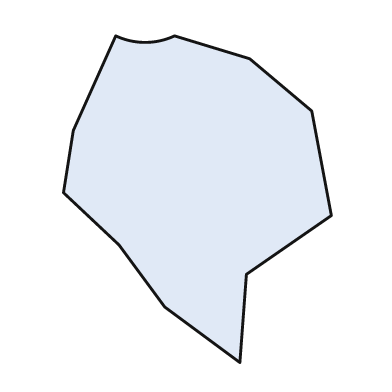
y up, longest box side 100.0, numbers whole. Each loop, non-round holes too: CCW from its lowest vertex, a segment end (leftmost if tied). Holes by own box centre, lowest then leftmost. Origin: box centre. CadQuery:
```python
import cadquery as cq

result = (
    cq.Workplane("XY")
    .moveTo(13.0, -50.0)
    .lineTo(15.0, -23.0)
    .lineTo(41.0, -5.0)
    .lineTo(35.0, 27.0)
    .lineTo(16.0, 43.0)
    .lineTo(-7.0, 50.0)
    .threePointArc((-16.0, 48.0), (-25.0, 50.0))
    .lineTo(-38.0, 21.0)
    .lineTo(-41.0, 2.0)
    .lineTo(-24.0, -14.0)
    .lineTo(-10.0, -33.0)
    .close()
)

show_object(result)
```